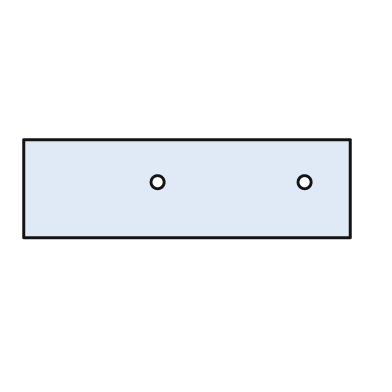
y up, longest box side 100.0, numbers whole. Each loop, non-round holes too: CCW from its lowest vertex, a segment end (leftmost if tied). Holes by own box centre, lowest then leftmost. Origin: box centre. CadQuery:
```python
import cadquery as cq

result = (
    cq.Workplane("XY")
    .moveTo(-50.0, -15.0)
    .lineTo(50.0, -15.0)
    .lineTo(50.0, 15.0)
    .lineTo(-50.0, 15.0)
    .close()
    .moveTo(-9.0, 2.0)
    .circle(2.0)
    .moveTo(36.0, 2.0)
    .circle(2.0)
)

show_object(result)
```